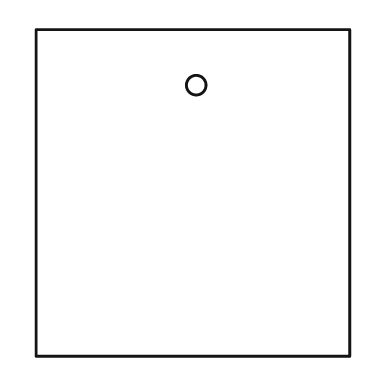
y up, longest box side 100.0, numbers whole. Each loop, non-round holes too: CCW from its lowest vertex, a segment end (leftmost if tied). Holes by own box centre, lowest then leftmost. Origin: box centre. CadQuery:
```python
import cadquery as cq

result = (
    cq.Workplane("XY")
    .moveTo(-48.0, -50.0)
    .lineTo(48.0, -50.0)
    .lineTo(48.0, 50.0)
    .lineTo(-48.0, 50.0)
    .close()
    .moveTo(1.0, 33.0)
    .circle(3.0)
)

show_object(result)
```